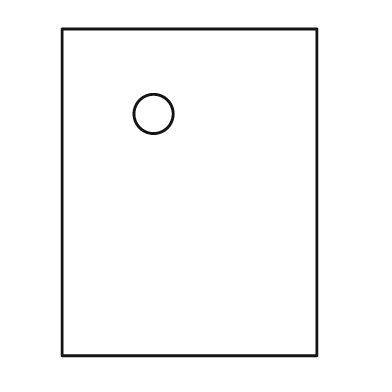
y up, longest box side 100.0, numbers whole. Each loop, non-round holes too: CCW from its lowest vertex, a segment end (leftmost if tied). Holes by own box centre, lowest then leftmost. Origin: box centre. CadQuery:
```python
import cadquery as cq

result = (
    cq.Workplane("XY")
    .moveTo(-39.0, -50.0)
    .lineTo(39.0, -50.0)
    .lineTo(39.0, 50.0)
    .lineTo(-39.0, 50.0)
    .close()
    .moveTo(-11.0, 24.0)
    .circle(6.0)
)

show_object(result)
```